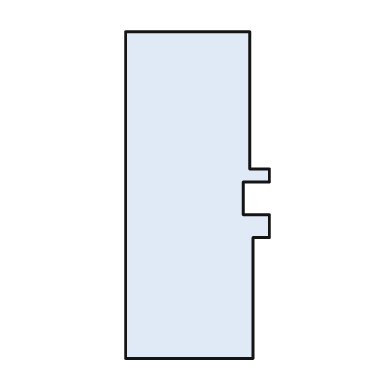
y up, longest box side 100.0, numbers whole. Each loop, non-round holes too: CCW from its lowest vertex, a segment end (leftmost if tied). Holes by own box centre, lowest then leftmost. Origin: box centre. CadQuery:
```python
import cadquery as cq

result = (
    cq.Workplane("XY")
    .moveTo(-22.0, -50.0)
    .lineTo(17.0, -50.0)
    .lineTo(17.0, -13.0)
    .lineTo(22.0, -13.0)
    .lineTo(22.0, -6.0)
    .lineTo(14.0, -6.0)
    .lineTo(14.0, 4.0)
    .lineTo(22.0, 4.0)
    .lineTo(22.0, 8.0)
    .lineTo(16.0, 8.0)
    .lineTo(16.0, 50.0)
    .lineTo(-22.0, 50.0)
    .close()
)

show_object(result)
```